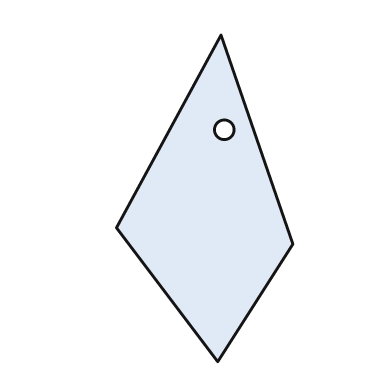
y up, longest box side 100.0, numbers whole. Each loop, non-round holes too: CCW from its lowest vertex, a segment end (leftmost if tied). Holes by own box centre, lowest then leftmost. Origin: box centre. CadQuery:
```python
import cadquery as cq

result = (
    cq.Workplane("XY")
    .moveTo(4.0, -50.0)
    .lineTo(27.0, -14.0)
    .lineTo(5.0, 50.0)
    .lineTo(-27.0, -9.0)
    .close()
    .moveTo(6.0, 21.0)
    .circle(3.0)
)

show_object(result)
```